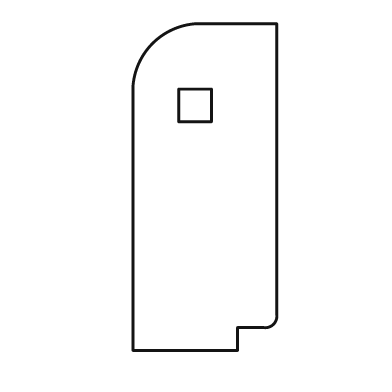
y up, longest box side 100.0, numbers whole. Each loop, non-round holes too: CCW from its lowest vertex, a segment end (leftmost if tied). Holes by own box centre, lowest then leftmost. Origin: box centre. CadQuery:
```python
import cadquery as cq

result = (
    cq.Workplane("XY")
    .moveTo(-22.0, -50.0)
    .lineTo(10.0, -50.0)
    .lineTo(10.0, -43.0)
    .lineTo(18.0, -43.0)
    .threePointArc((21.0, -42.0), (22.0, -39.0))
    .lineTo(22.0, 50.0)
    .lineTo(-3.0, 50.0)
    .threePointArc((-16.0, 44.0), (-22.0, 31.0))
    .close()
    .moveTo(-8.0, 20.0)
    .lineTo(2.0, 20.0)
    .lineTo(2.0, 30.0)
    .lineTo(-8.0, 30.0)
    .close()
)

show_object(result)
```